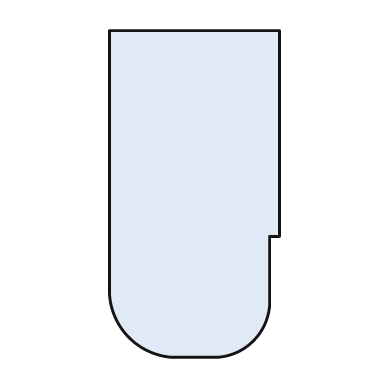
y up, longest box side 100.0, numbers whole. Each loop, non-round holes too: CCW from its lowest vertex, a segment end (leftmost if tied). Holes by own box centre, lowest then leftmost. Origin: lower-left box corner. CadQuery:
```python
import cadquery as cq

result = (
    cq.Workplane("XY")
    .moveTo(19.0, 0.0)
    .lineTo(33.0, 0.0)
    .threePointArc((44.0, 5.0), (49.0, 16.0))
    .lineTo(49.0, 37.0)
    .lineTo(52.0, 37.0)
    .lineTo(52.0, 100.0)
    .lineTo(0.0, 100.0)
    .lineTo(0.0, 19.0)
    .threePointArc((6.0, 6.0), (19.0, 0.0))
    .close()
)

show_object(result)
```